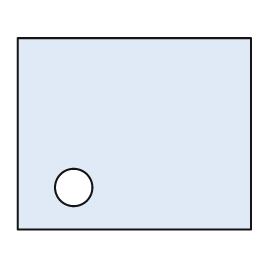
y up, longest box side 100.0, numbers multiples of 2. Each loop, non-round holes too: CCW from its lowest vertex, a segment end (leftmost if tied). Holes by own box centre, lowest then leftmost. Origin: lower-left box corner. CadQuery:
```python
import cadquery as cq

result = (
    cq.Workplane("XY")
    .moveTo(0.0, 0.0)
    .lineTo(100.0, 0.0)
    .lineTo(100.0, 82.0)
    .lineTo(0.0, 82.0)
    .close()
    .moveTo(24.0, 18.0)
    .circle(8.0)
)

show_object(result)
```